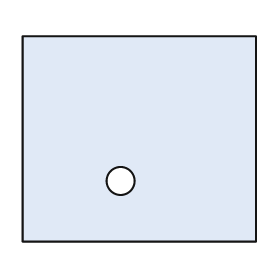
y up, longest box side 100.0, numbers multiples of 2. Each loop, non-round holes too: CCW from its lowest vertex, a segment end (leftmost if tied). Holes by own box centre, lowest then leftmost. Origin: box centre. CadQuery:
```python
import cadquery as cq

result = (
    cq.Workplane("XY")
    .moveTo(-50.0, -44.0)
    .lineTo(50.0, -44.0)
    .lineTo(50.0, 44.0)
    .lineTo(-50.0, 44.0)
    .close()
    .moveTo(-8.0, -18.0)
    .circle(6.0)
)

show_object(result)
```